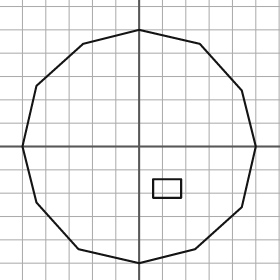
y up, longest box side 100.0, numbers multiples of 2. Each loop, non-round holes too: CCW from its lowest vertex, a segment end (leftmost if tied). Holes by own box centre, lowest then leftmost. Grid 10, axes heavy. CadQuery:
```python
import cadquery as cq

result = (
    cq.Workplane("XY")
    .moveTo(0.0, -50.0)
    .lineTo(24.0, -44.0)
    .lineTo(44.0, -26.0)
    .lineTo(50.0, 0.0)
    .lineTo(44.0, 24.0)
    .lineTo(26.0, 44.0)
    .lineTo(0.0, 50.0)
    .lineTo(-24.0, 44.0)
    .lineTo(-44.0, 26.0)
    .lineTo(-50.0, 0.0)
    .lineTo(-44.0, -24.0)
    .lineTo(-26.0, -44.0)
    .close()
    .moveTo(6.0, -22.0)
    .lineTo(18.0, -22.0)
    .lineTo(18.0, -14.0)
    .lineTo(6.0, -14.0)
    .close()
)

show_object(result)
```